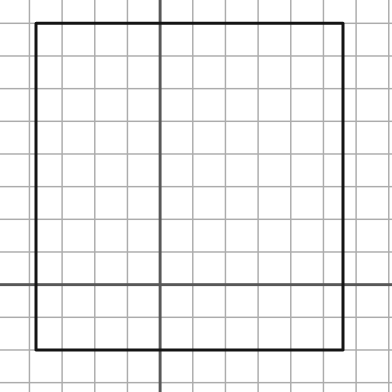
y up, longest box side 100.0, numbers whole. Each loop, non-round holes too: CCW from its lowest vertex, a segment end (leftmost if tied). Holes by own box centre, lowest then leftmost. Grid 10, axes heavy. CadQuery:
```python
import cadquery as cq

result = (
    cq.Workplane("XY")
    .moveTo(-38.0, -20.0)
    .lineTo(56.0, -20.0)
    .lineTo(56.0, 80.0)
    .lineTo(-38.0, 80.0)
    .close()
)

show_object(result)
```